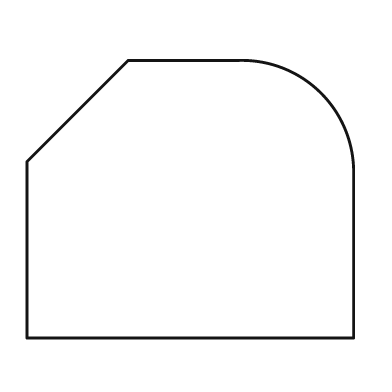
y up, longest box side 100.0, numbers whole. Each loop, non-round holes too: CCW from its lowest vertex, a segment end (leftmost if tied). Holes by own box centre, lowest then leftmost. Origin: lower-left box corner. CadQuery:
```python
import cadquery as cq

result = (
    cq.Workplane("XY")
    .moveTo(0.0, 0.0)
    .lineTo(100.0, 0.0)
    .lineTo(100.0, 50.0)
    .threePointArc((90.0, 75.0), (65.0, 85.0))
    .lineTo(31.0, 85.0)
    .lineTo(0.0, 54.0)
    .close()
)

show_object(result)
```